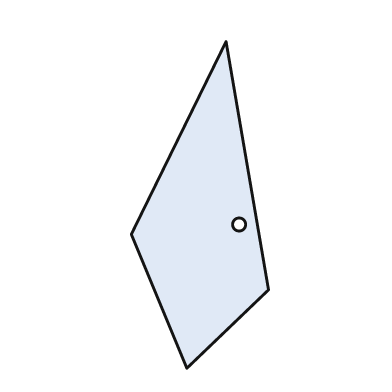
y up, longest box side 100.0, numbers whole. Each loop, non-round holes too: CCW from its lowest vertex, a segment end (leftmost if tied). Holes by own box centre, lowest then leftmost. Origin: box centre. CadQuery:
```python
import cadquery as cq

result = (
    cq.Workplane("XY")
    .moveTo(-4.0, -50.0)
    .lineTo(21.0, -26.0)
    .lineTo(8.0, 50.0)
    .lineTo(-21.0, -9.0)
    .close()
    .moveTo(12.0, -6.0)
    .circle(2.0)
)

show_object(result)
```